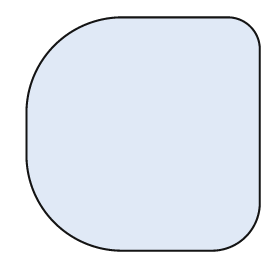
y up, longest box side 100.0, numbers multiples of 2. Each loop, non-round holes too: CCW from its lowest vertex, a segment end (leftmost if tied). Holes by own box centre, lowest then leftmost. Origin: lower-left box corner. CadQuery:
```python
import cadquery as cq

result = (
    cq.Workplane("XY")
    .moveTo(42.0, 0.0)
    .lineTo(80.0, 0.0)
    .threePointArc((94.0, 6.0), (100.0, 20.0))
    .lineTo(100.0, 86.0)
    .threePointArc((96.0, 96.0), (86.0, 100.0))
    .lineTo(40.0, 100.0)
    .threePointArc((12.0, 88.0), (0.0, 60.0))
    .lineTo(0.0, 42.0)
    .threePointArc((12.0, 12.0), (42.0, 0.0))
    .close()
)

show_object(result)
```